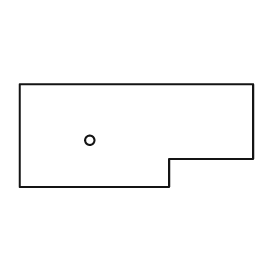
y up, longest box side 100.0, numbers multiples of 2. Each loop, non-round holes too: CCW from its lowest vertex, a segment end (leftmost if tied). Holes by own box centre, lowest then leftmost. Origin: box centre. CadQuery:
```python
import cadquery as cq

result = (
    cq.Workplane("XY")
    .moveTo(-50.0, -22.0)
    .lineTo(14.0, -22.0)
    .lineTo(14.0, -10.0)
    .lineTo(50.0, -10.0)
    .lineTo(50.0, 22.0)
    .lineTo(-50.0, 22.0)
    .close()
    .moveTo(-20.0, -2.0)
    .circle(2.0)
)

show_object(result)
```